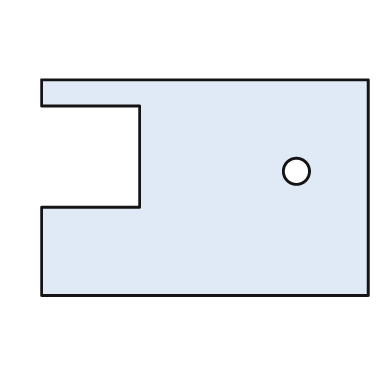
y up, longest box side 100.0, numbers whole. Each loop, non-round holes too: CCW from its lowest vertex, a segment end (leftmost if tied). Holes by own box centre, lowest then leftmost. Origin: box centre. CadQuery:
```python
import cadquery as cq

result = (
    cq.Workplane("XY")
    .moveTo(-50.0, -33.0)
    .lineTo(50.0, -33.0)
    .lineTo(50.0, 33.0)
    .lineTo(-50.0, 33.0)
    .lineTo(-50.0, 25.0)
    .lineTo(-20.0, 25.0)
    .lineTo(-20.0, -6.0)
    .lineTo(-50.0, -6.0)
    .close()
    .moveTo(28.0, 5.0)
    .circle(4.0)
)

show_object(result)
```